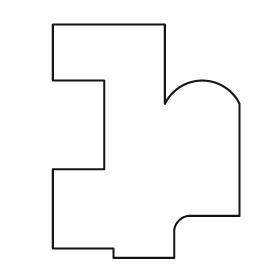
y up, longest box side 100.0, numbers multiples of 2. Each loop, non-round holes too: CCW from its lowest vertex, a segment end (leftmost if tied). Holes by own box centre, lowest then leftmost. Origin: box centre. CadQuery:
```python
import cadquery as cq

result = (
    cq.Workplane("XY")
    .moveTo(-14.0, -50.0)
    .lineTo(12.0, -50.0)
    .lineTo(12.0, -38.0)
    .threePointArc((14.0, -34.0), (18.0, -32.0))
    .lineTo(40.0, -32.0)
    .lineTo(40.0, 16.0)
    .threePointArc((24.0, 26.0), (8.0, 16.0))
    .lineTo(8.0, 50.0)
    .lineTo(-40.0, 50.0)
    .lineTo(-40.0, 26.0)
    .lineTo(-18.0, 26.0)
    .lineTo(-18.0, -12.0)
    .lineTo(-40.0, -12.0)
    .lineTo(-40.0, -46.0)
    .lineTo(-14.0, -46.0)
    .close()
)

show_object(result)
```